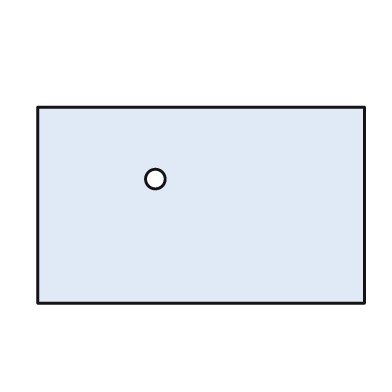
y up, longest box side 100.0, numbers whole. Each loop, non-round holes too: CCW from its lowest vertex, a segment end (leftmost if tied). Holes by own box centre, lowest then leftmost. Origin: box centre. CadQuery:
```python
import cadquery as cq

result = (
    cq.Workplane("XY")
    .moveTo(-50.0, -30.0)
    .lineTo(50.0, -30.0)
    .lineTo(50.0, 30.0)
    .lineTo(-50.0, 30.0)
    .close()
    .moveTo(-14.0, 8.0)
    .circle(3.0)
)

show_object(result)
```